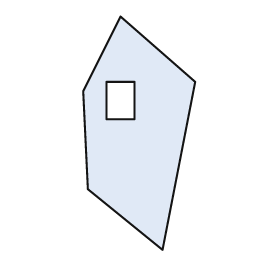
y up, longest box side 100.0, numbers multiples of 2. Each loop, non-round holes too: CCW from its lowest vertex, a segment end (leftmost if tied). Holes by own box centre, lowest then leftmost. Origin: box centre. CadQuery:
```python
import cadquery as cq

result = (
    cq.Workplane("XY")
    .moveTo(10.0, -50.0)
    .lineTo(24.0, 22.0)
    .lineTo(-8.0, 50.0)
    .lineTo(-24.0, 18.0)
    .lineTo(-22.0, -24.0)
    .close()
    .moveTo(-14.0, 6.0)
    .lineTo(-2.0, 6.0)
    .lineTo(-2.0, 22.0)
    .lineTo(-14.0, 22.0)
    .close()
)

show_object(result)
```